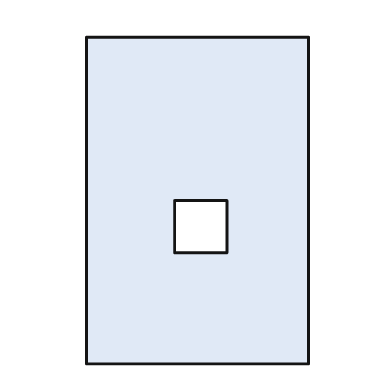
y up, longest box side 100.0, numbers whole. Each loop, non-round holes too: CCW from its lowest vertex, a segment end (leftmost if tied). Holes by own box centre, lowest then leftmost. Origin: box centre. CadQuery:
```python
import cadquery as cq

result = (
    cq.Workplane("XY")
    .moveTo(-34.0, -50.0)
    .lineTo(34.0, -50.0)
    .lineTo(34.0, 50.0)
    .lineTo(-34.0, 50.0)
    .close()
    .moveTo(-7.0, -16.0)
    .lineTo(9.0, -16.0)
    .lineTo(9.0, 0.0)
    .lineTo(-7.0, 0.0)
    .close()
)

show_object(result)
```